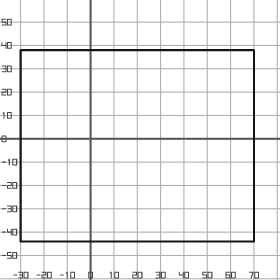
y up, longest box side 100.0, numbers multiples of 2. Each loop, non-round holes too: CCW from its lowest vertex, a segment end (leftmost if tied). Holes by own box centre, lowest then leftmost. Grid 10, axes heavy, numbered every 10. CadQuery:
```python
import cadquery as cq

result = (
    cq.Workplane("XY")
    .moveTo(-30.0, -44.0)
    .lineTo(70.0, -44.0)
    .lineTo(70.0, 38.0)
    .lineTo(-30.0, 38.0)
    .close()
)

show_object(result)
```